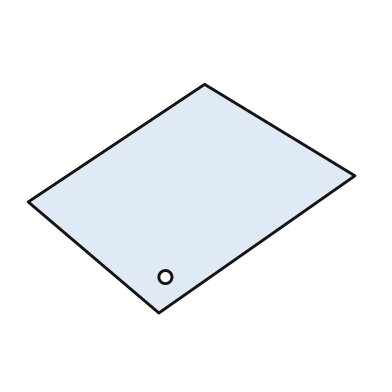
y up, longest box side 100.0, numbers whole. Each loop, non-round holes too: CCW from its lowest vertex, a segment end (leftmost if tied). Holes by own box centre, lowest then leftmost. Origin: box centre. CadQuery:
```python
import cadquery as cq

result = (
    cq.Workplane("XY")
    .moveTo(-10.0, -35.0)
    .lineTo(50.0, 7.0)
    .lineTo(4.0, 35.0)
    .lineTo(-50.0, -1.0)
    .close()
    .moveTo(-8.0, -24.0)
    .circle(2.0)
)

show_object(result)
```